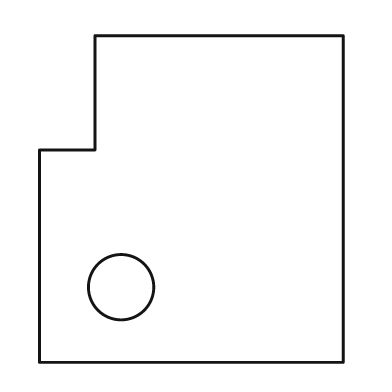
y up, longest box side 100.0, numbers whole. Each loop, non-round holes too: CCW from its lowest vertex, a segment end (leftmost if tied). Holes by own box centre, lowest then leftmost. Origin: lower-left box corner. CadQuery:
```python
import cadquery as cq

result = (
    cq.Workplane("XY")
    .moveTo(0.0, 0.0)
    .lineTo(93.0, 0.0)
    .lineTo(93.0, 100.0)
    .lineTo(17.0, 100.0)
    .lineTo(17.0, 65.0)
    .lineTo(0.0, 65.0)
    .close()
    .moveTo(25.0, 23.0)
    .circle(10.0)
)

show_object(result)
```